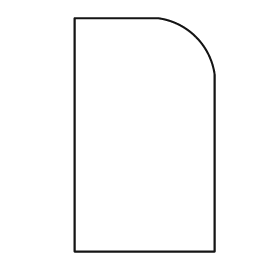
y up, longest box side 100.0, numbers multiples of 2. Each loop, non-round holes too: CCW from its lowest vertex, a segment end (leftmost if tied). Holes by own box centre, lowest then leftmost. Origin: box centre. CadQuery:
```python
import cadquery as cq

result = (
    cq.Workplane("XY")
    .moveTo(-30.0, -50.0)
    .lineTo(30.0, -50.0)
    .lineTo(30.0, 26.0)
    .threePointArc((22.0, 42.0), (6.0, 50.0))
    .lineTo(-30.0, 50.0)
    .close()
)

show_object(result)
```